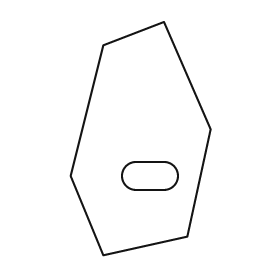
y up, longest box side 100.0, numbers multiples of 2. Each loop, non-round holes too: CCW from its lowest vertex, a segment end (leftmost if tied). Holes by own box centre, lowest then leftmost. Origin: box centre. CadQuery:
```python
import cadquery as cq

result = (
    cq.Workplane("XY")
    .moveTo(-16.0, -50.0)
    .lineTo(20.0, -42.0)
    .lineTo(30.0, 4.0)
    .lineTo(10.0, 50.0)
    .lineTo(-16.0, 40.0)
    .lineTo(-30.0, -16.0)
    .close()
    .moveTo(-2.0, -22.0)
    .lineTo(10.0, -22.0)
    .threePointArc((16.0, -16.0), (10.0, -10.0))
    .lineTo(-2.0, -10.0)
    .threePointArc((-8.0, -16.0), (-2.0, -22.0))
    .close()
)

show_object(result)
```